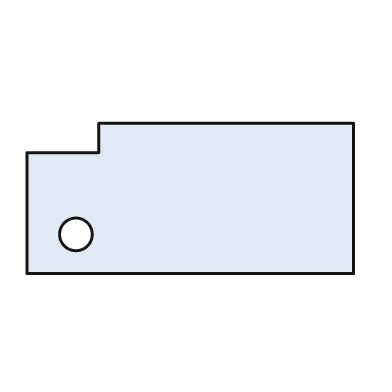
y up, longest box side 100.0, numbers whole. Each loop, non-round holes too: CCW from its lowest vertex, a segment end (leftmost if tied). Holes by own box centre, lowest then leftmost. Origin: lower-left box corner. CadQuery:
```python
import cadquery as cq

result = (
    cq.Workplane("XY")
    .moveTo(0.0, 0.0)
    .lineTo(100.0, 0.0)
    .lineTo(100.0, 46.0)
    .lineTo(22.0, 46.0)
    .lineTo(22.0, 37.0)
    .lineTo(0.0, 37.0)
    .close()
    .moveTo(15.0, 12.0)
    .circle(5.0)
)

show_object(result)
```